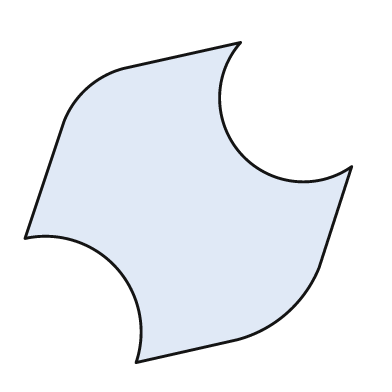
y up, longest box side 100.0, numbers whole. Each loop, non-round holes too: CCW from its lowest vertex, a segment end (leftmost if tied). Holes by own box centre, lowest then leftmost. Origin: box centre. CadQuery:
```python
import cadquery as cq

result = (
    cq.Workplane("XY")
    .moveTo(-16.0, -49.0)
    .lineTo(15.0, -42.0)
    .threePointArc((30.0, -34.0), (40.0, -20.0))
    .lineTo(50.0, 11.0)
    .threePointArc((16.0, 15.0), (16.0, 49.0))
    .lineTo(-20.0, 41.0)
    .threePointArc((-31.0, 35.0), (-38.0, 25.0))
    .lineTo(-50.0, -11.0)
    .threePointArc((-22.0, -20.0), (-16.0, -49.0))
    .close()
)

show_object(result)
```